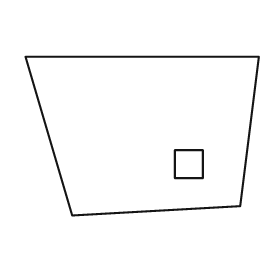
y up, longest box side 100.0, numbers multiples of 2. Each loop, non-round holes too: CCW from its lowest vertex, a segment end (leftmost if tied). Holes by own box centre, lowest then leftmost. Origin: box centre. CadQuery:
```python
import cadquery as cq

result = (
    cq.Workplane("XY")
    .moveTo(-30.0, -34.0)
    .lineTo(42.0, -30.0)
    .lineTo(50.0, 34.0)
    .lineTo(-50.0, 34.0)
    .close()
    .moveTo(14.0, -18.0)
    .lineTo(26.0, -18.0)
    .lineTo(26.0, -6.0)
    .lineTo(14.0, -6.0)
    .close()
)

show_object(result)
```